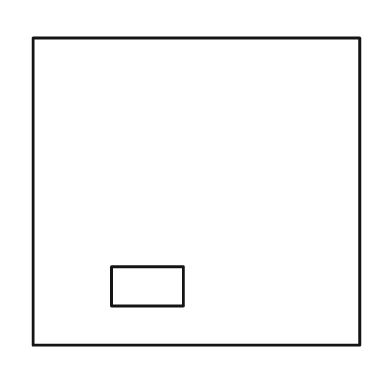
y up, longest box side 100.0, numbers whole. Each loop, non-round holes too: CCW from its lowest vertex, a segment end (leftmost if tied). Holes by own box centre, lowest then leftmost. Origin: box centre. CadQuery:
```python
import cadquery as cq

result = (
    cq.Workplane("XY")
    .moveTo(-50.0, -47.0)
    .lineTo(50.0, -47.0)
    .lineTo(50.0, 47.0)
    .lineTo(-50.0, 47.0)
    .close()
    .moveTo(-26.0, -35.0)
    .lineTo(-4.0, -35.0)
    .lineTo(-4.0, -23.0)
    .lineTo(-26.0, -23.0)
    .close()
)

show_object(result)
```